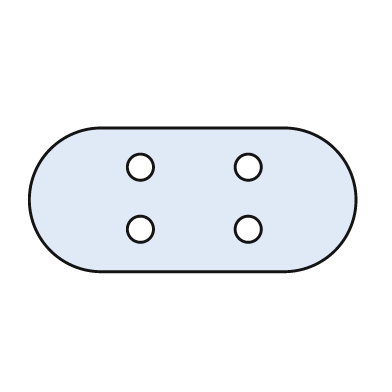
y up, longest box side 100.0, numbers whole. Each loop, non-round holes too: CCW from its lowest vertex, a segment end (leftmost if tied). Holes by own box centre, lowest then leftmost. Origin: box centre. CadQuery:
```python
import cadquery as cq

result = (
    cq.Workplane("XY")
    .moveTo(-28.0, -22.0)
    .lineTo(28.0, -22.0)
    .threePointArc((50.0, 0.0), (28.0, 22.0))
    .lineTo(-28.0, 22.0)
    .threePointArc((-50.0, 0.0), (-28.0, -22.0))
    .close()
    .moveTo(-16.0, -9.0)
    .circle(4.0)
    .moveTo(17.0, -9.0)
    .circle(4.0)
    .moveTo(-16.0, 10.0)
    .circle(4.0)
    .moveTo(17.0, 10.0)
    .circle(4.0)
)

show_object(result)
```